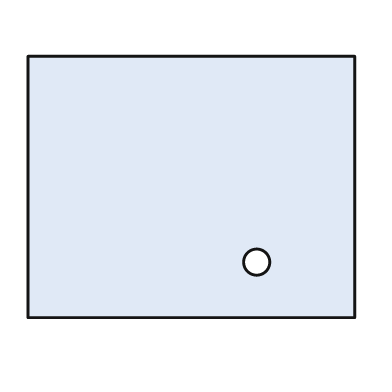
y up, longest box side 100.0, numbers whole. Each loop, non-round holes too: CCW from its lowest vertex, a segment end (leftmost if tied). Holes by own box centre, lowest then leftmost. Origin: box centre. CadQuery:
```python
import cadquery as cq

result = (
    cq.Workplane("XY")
    .moveTo(-50.0, -40.0)
    .lineTo(50.0, -40.0)
    .lineTo(50.0, 40.0)
    .lineTo(-50.0, 40.0)
    .close()
    .moveTo(20.0, -23.0)
    .circle(4.0)
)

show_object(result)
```